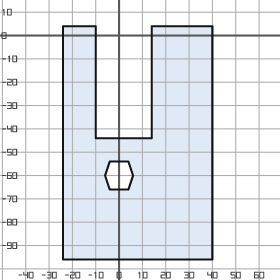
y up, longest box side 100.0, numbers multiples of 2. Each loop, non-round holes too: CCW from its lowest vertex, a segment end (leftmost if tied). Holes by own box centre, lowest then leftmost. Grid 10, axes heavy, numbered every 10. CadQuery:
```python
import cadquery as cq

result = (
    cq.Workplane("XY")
    .moveTo(-24.0, -96.0)
    .lineTo(40.0, -96.0)
    .lineTo(40.0, 4.0)
    .lineTo(14.0, 4.0)
    .lineTo(14.0, -44.0)
    .lineTo(-10.0, -44.0)
    .lineTo(-10.0, 4.0)
    .lineTo(-24.0, 4.0)
    .close()
    .moveTo(-4.0, -66.0)
    .lineTo(4.0, -66.0)
    .lineTo(6.0, -60.0)
    .lineTo(4.0, -54.0)
    .lineTo(-4.0, -54.0)
    .lineTo(-6.0, -60.0)
    .close()
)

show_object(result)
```